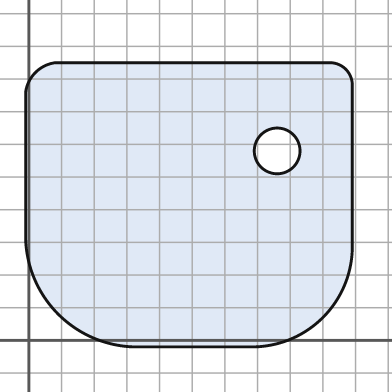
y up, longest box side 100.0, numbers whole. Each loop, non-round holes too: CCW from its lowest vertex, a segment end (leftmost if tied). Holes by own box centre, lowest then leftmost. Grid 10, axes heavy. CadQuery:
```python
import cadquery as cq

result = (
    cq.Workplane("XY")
    .moveTo(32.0, -2.0)
    .lineTo(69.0, -2.0)
    .threePointArc((90.0, 7.0), (99.0, 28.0))
    .lineTo(99.0, 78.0)
    .threePointArc((97.0, 83.0), (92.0, 85.0))
    .lineTo(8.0, 85.0)
    .threePointArc((2.0, 82.0), (-1.0, 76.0))
    .lineTo(-1.0, 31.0)
    .threePointArc((9.0, 8.0), (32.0, -2.0))
    .close()
    .moveTo(76.0, 58.0)
    .circle(7.0)
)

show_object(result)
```